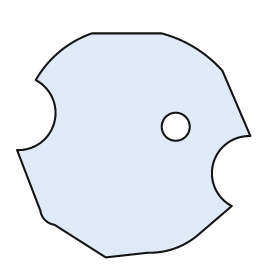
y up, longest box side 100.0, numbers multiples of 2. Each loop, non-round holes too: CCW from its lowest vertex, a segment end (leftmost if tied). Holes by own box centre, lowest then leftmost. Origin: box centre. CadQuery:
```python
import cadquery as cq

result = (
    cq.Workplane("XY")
    .moveTo(-12.0, -48.0)
    .lineTo(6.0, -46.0)
    .threePointArc((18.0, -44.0), (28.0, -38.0))
    .lineTo(42.0, -26.0)
    .threePointArc((34.0, -8.0), (50.0, 4.0))
    .lineTo(38.0, 32.0)
    .threePointArc((26.0, 42.0), (12.0, 48.0))
    .lineTo(-18.0, 48.0)
    .threePointArc((-32.0, 40.0), (-42.0, 28.0))
    .threePointArc((-34.0, 10.0), (-50.0, -2.0))
    .lineTo(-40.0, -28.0)
    .threePointArc((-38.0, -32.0), (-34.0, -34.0))
    .close()
    .moveTo(18.0, 8.0)
    .circle(6.0)
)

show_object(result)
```